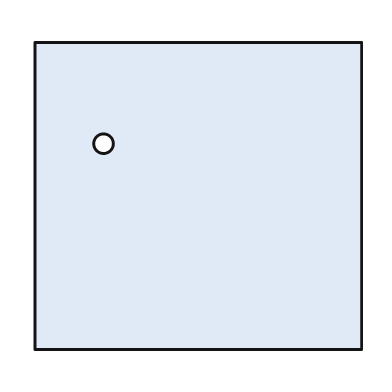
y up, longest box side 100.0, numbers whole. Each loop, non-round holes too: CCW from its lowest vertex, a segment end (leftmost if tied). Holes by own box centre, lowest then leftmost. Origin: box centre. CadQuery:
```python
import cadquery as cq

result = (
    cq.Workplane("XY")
    .moveTo(-50.0, -47.0)
    .lineTo(50.0, -47.0)
    .lineTo(50.0, 47.0)
    .lineTo(-50.0, 47.0)
    .close()
    .moveTo(-29.0, 16.0)
    .circle(3.0)
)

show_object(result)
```